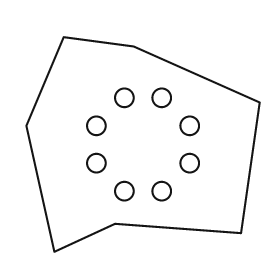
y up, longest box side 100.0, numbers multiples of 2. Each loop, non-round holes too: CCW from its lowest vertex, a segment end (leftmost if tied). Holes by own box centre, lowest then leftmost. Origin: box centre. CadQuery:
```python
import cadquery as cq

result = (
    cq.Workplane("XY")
    .moveTo(-38.0, -46.0)
    .lineTo(-12.0, -34.0)
    .lineTo(42.0, -38.0)
    .lineTo(50.0, 18.0)
    .lineTo(-4.0, 42.0)
    .lineTo(-34.0, 46.0)
    .lineTo(-50.0, 8.0)
    .close()
    .moveTo(-8.0, -20.0)
    .circle(4.0)
    .moveTo(8.0, -20.0)
    .circle(4.0)
    .moveTo(-20.0, -8.0)
    .circle(4.0)
    .moveTo(20.0, -8.0)
    .circle(4.0)
    .moveTo(-20.0, 8.0)
    .circle(4.0)
    .moveTo(20.0, 8.0)
    .circle(4.0)
    .moveTo(-8.0, 20.0)
    .circle(4.0)
    .moveTo(8.0, 20.0)
    .circle(4.0)
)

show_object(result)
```